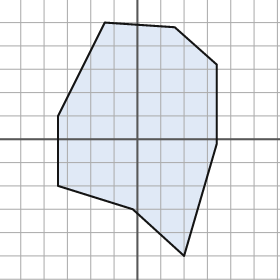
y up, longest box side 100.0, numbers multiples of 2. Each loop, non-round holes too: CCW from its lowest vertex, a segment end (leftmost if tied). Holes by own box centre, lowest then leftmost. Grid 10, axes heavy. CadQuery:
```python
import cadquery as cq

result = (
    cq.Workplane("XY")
    .moveTo(20.0, -50.0)
    .lineTo(34.0, -2.0)
    .lineTo(34.0, 32.0)
    .lineTo(16.0, 48.0)
    .lineTo(-14.0, 50.0)
    .lineTo(-34.0, 10.0)
    .lineTo(-34.0, -20.0)
    .lineTo(-2.0, -30.0)
    .close()
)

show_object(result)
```